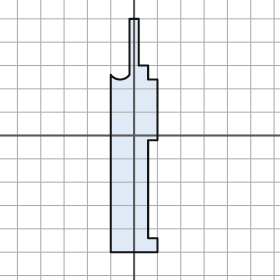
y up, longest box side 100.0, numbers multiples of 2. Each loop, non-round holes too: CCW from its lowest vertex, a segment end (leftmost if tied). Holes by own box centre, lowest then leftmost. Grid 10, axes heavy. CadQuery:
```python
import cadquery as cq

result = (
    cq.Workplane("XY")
    .moveTo(-10.0, -50.0)
    .lineTo(10.0, -50.0)
    .lineTo(10.0, -44.0)
    .lineTo(6.0, -44.0)
    .lineTo(6.0, -2.0)
    .lineTo(10.0, -2.0)
    .lineTo(10.0, 24.0)
    .lineTo(6.0, 24.0)
    .lineTo(6.0, 30.0)
    .lineTo(2.0, 30.0)
    .lineTo(2.0, 50.0)
    .lineTo(-2.0, 50.0)
    .lineTo(-2.0, 26.0)
    .threePointArc((-6.0, 24.0), (-10.0, 26.0))
    .close()
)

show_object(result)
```